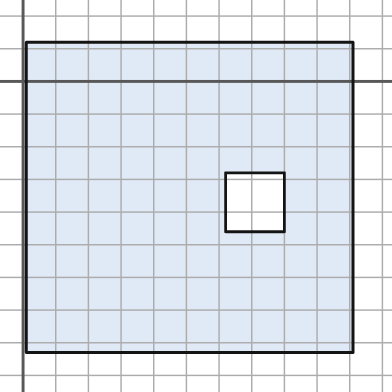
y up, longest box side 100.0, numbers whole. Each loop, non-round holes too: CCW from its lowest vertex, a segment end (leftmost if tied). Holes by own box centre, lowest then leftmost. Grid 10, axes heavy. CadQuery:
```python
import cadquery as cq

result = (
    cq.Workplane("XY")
    .moveTo(1.0, -83.0)
    .lineTo(101.0, -83.0)
    .lineTo(101.0, 12.0)
    .lineTo(1.0, 12.0)
    .close()
    .moveTo(62.0, -46.0)
    .lineTo(80.0, -46.0)
    .lineTo(80.0, -28.0)
    .lineTo(62.0, -28.0)
    .close()
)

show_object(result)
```